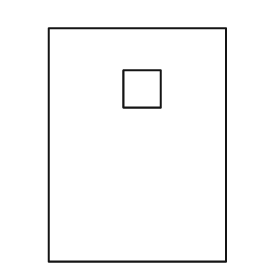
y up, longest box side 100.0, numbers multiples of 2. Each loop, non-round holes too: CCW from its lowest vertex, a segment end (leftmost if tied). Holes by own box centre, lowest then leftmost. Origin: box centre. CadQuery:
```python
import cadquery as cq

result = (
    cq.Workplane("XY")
    .moveTo(-38.0, -50.0)
    .lineTo(38.0, -50.0)
    .lineTo(38.0, 50.0)
    .lineTo(-38.0, 50.0)
    .close()
    .moveTo(-6.0, 16.0)
    .lineTo(10.0, 16.0)
    .lineTo(10.0, 32.0)
    .lineTo(-6.0, 32.0)
    .close()
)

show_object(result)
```